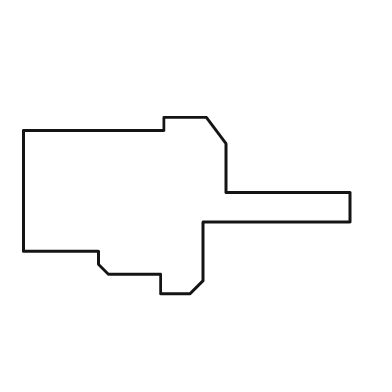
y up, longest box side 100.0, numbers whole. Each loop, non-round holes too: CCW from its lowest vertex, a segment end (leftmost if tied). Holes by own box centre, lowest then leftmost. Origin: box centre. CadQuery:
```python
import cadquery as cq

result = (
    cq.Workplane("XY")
    .moveTo(-8.0, -27.0)
    .lineTo(1.0, -27.0)
    .lineTo(5.0, -23.0)
    .lineTo(5.0, -5.0)
    .lineTo(50.0, -5.0)
    .lineTo(50.0, 4.0)
    .lineTo(12.0, 4.0)
    .lineTo(12.0, 19.0)
    .lineTo(6.0, 27.0)
    .lineTo(-7.0, 27.0)
    .lineTo(-7.0, 23.0)
    .lineTo(-50.0, 23.0)
    .lineTo(-50.0, -14.0)
    .lineTo(-27.0, -14.0)
    .lineTo(-27.0, -18.0)
    .lineTo(-24.0, -21.0)
    .lineTo(-8.0, -21.0)
    .close()
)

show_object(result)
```